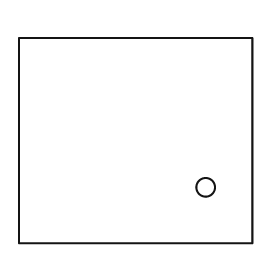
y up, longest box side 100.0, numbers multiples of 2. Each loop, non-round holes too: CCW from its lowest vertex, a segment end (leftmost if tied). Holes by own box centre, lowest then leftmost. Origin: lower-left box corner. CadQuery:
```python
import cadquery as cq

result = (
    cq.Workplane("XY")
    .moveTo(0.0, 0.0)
    .lineTo(100.0, 0.0)
    .lineTo(100.0, 88.0)
    .lineTo(0.0, 88.0)
    .close()
    .moveTo(80.0, 24.0)
    .circle(4.0)
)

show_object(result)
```